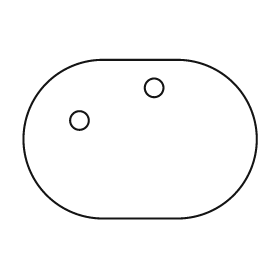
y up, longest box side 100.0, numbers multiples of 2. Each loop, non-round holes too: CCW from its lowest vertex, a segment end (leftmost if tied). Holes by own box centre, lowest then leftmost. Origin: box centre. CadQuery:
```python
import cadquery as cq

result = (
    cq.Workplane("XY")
    .moveTo(-16.0, -34.0)
    .lineTo(16.0, -34.0)
    .threePointArc((50.0, 0.0), (16.0, 34.0))
    .lineTo(-16.0, 34.0)
    .threePointArc((-50.0, 0.0), (-16.0, -34.0))
    .close()
    .moveTo(-26.0, 8.0)
    .circle(4.0)
    .moveTo(6.0, 22.0)
    .circle(4.0)
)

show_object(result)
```